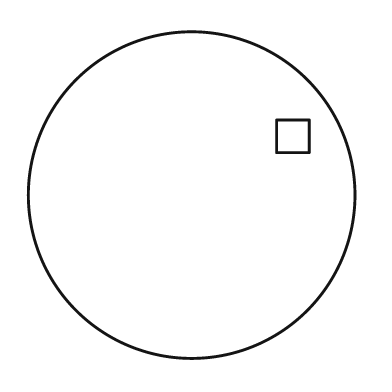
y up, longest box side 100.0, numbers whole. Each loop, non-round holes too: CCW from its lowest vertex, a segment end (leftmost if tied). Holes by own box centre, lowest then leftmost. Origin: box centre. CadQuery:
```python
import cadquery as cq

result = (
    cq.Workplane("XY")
    .moveTo(0.0, 0.0)
    .circle(50.0)
    .moveTo(26.0, 13.0)
    .lineTo(36.0, 13.0)
    .lineTo(36.0, 23.0)
    .lineTo(26.0, 23.0)
    .close()
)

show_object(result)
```